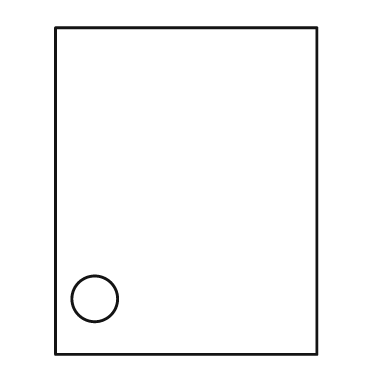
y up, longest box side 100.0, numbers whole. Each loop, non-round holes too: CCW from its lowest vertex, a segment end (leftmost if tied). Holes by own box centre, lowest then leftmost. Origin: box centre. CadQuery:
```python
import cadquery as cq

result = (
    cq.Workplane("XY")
    .moveTo(-40.0, -50.0)
    .lineTo(40.0, -50.0)
    .lineTo(40.0, 50.0)
    .lineTo(-40.0, 50.0)
    .close()
    .moveTo(-28.0, -33.0)
    .circle(7.0)
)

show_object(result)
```